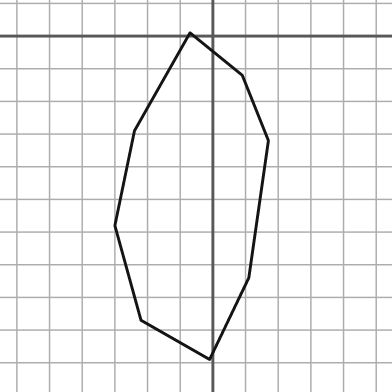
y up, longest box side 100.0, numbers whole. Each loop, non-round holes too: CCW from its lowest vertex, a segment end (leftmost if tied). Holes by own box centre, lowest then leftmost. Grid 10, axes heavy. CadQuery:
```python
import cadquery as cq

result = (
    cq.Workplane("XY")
    .moveTo(-1.0, -99.0)
    .lineTo(11.0, -74.0)
    .lineTo(17.0, -32.0)
    .lineTo(9.0, -12.0)
    .lineTo(-7.0, 1.0)
    .lineTo(-24.0, -29.0)
    .lineTo(-30.0, -58.0)
    .lineTo(-22.0, -87.0)
    .close()
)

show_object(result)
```